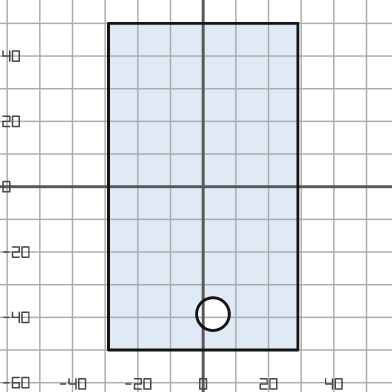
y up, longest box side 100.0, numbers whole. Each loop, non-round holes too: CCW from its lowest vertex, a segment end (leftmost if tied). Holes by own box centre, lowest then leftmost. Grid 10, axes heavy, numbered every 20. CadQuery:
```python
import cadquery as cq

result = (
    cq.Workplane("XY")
    .moveTo(-29.0, -50.0)
    .lineTo(29.0, -50.0)
    .lineTo(29.0, 50.0)
    .lineTo(-29.0, 50.0)
    .close()
    .moveTo(3.0, -39.0)
    .circle(5.0)
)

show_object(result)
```